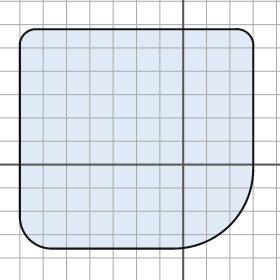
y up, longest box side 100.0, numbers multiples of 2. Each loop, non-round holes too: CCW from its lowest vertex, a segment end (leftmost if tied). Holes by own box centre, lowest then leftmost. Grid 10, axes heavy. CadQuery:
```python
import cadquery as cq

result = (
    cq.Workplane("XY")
    .moveTo(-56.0, -36.0)
    .lineTo(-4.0, -36.0)
    .threePointArc((20.0, -26.0), (30.0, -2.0))
    .lineTo(30.0, 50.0)
    .threePointArc((28.0, 56.0), (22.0, 58.0))
    .lineTo(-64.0, 58.0)
    .threePointArc((-68.0, 56.0), (-70.0, 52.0))
    .lineTo(-70.0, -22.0)
    .threePointArc((-66.0, -32.0), (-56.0, -36.0))
    .close()
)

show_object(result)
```